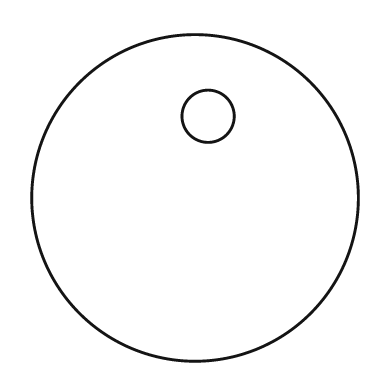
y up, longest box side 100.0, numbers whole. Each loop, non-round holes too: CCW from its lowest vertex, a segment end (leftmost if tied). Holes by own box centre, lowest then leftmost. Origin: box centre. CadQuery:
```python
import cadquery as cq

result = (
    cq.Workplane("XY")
    .moveTo(0.0, 0.0)
    .circle(50.0)
    .moveTo(4.0, 25.0)
    .circle(8.0)
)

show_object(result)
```